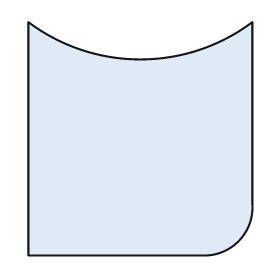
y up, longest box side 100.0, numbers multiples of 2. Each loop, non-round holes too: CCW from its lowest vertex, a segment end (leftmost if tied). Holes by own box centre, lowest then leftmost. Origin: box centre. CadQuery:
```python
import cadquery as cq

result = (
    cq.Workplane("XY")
    .moveTo(-48.0, -50.0)
    .lineTo(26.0, -50.0)
    .threePointArc((42.0, -44.0), (48.0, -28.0))
    .lineTo(48.0, 50.0)
    .threePointArc((0.0, 34.0), (-48.0, 50.0))
    .close()
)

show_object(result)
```